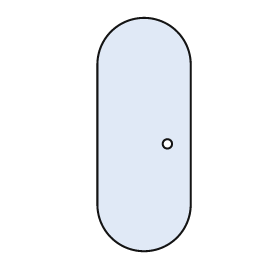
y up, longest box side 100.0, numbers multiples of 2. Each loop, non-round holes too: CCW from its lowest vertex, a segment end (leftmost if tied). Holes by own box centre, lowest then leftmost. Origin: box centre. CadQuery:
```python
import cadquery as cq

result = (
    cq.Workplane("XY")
    .moveTo(-20.0, -30.0)
    .threePointArc((0.0, -50.0), (20.0, -30.0))
    .lineTo(20.0, 30.0)
    .threePointArc((0.0, 50.0), (-20.0, 30.0))
    .close()
    .moveTo(10.0, -4.0)
    .circle(2.0)
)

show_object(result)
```